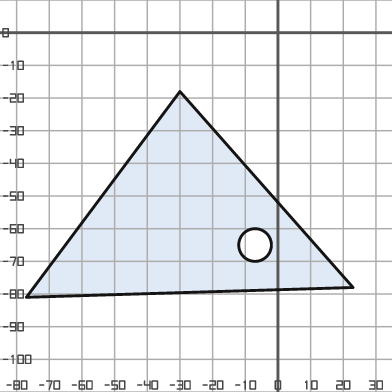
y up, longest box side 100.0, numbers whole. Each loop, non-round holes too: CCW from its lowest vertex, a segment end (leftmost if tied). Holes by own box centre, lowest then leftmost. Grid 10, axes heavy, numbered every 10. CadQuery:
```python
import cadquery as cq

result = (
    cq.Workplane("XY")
    .moveTo(-77.0, -81.0)
    .lineTo(23.0, -78.0)
    .lineTo(-30.0, -18.0)
    .close()
    .moveTo(-7.0, -65.0)
    .circle(5.0)
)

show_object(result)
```